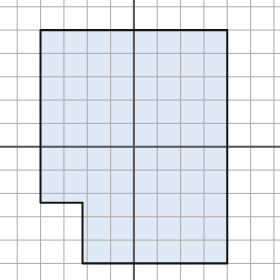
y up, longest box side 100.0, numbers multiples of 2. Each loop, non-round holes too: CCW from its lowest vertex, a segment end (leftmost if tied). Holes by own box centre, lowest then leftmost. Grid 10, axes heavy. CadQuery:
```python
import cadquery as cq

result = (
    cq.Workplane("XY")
    .moveTo(-22.0, -50.0)
    .lineTo(40.0, -50.0)
    .lineTo(40.0, 50.0)
    .lineTo(-40.0, 50.0)
    .lineTo(-40.0, -24.0)
    .lineTo(-22.0, -24.0)
    .close()
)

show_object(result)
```